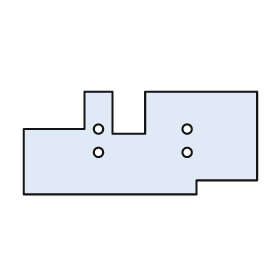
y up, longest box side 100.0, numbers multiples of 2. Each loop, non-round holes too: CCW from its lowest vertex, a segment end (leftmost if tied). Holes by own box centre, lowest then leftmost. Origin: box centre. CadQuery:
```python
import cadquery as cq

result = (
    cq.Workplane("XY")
    .moveTo(-50.0, -22.0)
    .lineTo(24.0, -22.0)
    .lineTo(24.0, -16.0)
    .lineTo(50.0, -16.0)
    .lineTo(50.0, 22.0)
    .lineTo(2.0, 22.0)
    .lineTo(2.0, 4.0)
    .lineTo(-12.0, 4.0)
    .lineTo(-12.0, 22.0)
    .lineTo(-24.0, 22.0)
    .lineTo(-24.0, 6.0)
    .lineTo(-50.0, 6.0)
    .close()
    .moveTo(-18.0, -4.0)
    .circle(2.0)
    .moveTo(20.0, -4.0)
    .circle(2.0)
    .moveTo(-18.0, 6.0)
    .circle(2.0)
    .moveTo(20.0, 6.0)
    .circle(2.0)
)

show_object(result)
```